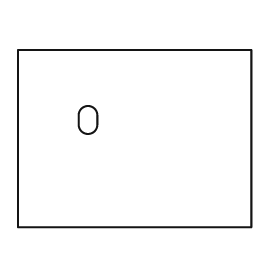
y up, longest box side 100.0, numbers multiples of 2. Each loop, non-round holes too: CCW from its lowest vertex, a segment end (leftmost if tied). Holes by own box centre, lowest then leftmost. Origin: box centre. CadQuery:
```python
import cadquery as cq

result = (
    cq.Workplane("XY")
    .moveTo(-50.0, -38.0)
    .lineTo(50.0, -38.0)
    .lineTo(50.0, 38.0)
    .lineTo(-50.0, 38.0)
    .close()
    .moveTo(-24.0, 6.0)
    .threePointArc((-20.0, 2.0), (-16.0, 6.0))
    .lineTo(-16.0, 10.0)
    .threePointArc((-20.0, 14.0), (-24.0, 10.0))
    .close()
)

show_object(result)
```